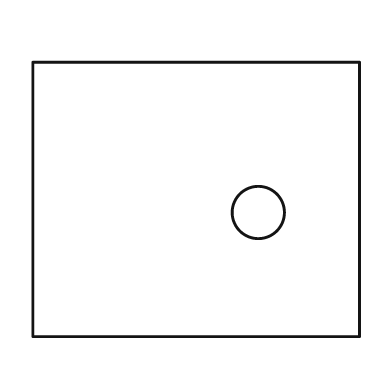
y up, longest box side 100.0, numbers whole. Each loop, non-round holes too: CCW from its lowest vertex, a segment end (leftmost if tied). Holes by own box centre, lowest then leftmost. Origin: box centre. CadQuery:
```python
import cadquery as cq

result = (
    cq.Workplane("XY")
    .moveTo(-50.0, -42.0)
    .lineTo(50.0, -42.0)
    .lineTo(50.0, 42.0)
    .lineTo(-50.0, 42.0)
    .close()
    .moveTo(19.0, -4.0)
    .circle(8.0)
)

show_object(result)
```